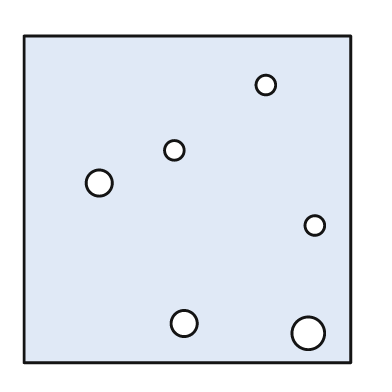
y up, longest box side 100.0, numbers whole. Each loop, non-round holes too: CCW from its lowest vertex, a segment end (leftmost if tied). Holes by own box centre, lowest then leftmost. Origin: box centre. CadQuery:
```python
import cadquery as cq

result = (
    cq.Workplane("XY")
    .moveTo(-50.0, -50.0)
    .lineTo(50.0, -50.0)
    .lineTo(50.0, 50.0)
    .lineTo(-50.0, 50.0)
    .close()
    .moveTo(37.0, -41.0)
    .circle(5.0)
    .moveTo(-1.0, -38.0)
    .circle(4.0)
    .moveTo(39.0, -8.0)
    .circle(3.0)
    .moveTo(-27.0, 5.0)
    .circle(4.0)
    .moveTo(-4.0, 15.0)
    .circle(3.0)
    .moveTo(24.0, 35.0)
    .circle(3.0)
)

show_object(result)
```